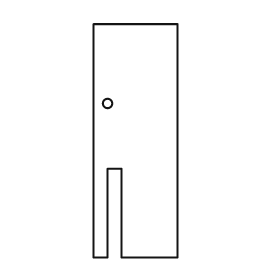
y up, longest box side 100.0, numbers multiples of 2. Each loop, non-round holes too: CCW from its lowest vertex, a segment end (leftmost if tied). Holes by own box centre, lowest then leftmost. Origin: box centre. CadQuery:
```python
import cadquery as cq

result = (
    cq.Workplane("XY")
    .moveTo(-18.0, -50.0)
    .lineTo(-12.0, -50.0)
    .lineTo(-12.0, -12.0)
    .lineTo(-6.0, -12.0)
    .lineTo(-6.0, -50.0)
    .lineTo(18.0, -50.0)
    .lineTo(18.0, 50.0)
    .lineTo(-18.0, 50.0)
    .close()
    .moveTo(-12.0, 16.0)
    .circle(2.0)
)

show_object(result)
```